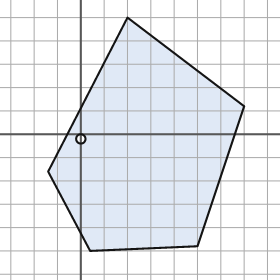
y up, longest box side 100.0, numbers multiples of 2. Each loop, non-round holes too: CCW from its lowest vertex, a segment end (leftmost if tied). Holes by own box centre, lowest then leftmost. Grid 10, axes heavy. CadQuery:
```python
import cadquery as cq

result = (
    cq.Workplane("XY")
    .moveTo(4.0, -50.0)
    .lineTo(50.0, -48.0)
    .lineTo(70.0, 12.0)
    .lineTo(20.0, 50.0)
    .lineTo(-14.0, -16.0)
    .close()
    .moveTo(0.0, -2.0)
    .circle(2.0)
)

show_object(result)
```